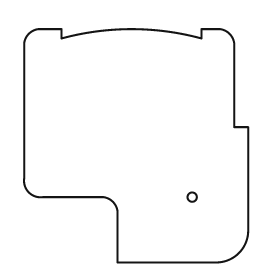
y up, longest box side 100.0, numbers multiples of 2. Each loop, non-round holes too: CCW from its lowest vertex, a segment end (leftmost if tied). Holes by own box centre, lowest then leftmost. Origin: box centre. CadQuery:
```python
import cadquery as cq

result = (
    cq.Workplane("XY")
    .moveTo(-8.0, -50.0)
    .lineTo(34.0, -50.0)
    .threePointArc((44.0, -46.0), (48.0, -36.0))
    .lineTo(48.0, 8.0)
    .lineTo(42.0, 8.0)
    .lineTo(42.0, 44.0)
    .threePointArc((40.0, 48.0), (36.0, 50.0))
    .lineTo(28.0, 50.0)
    .lineTo(28.0, 46.0)
    .threePointArc((-2.0, 50.0), (-32.0, 46.0))
    .lineTo(-32.0, 50.0)
    .lineTo(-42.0, 50.0)
    .threePointArc((-46.0, 48.0), (-48.0, 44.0))
    .lineTo(-48.0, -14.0)
    .threePointArc((-46.0, -20.0), (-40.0, -22.0))
    .lineTo(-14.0, -22.0)
    .threePointArc((-10.0, -24.0), (-8.0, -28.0))
    .close()
    .moveTo(24.0, -22.0)
    .circle(2.0)
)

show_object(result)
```